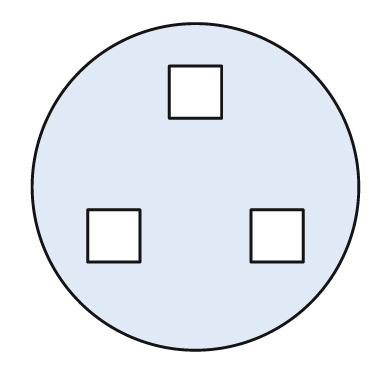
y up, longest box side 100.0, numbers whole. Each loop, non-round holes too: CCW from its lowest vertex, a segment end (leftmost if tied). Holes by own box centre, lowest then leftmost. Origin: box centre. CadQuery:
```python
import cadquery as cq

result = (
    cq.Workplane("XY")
    .moveTo(0.0, 0.0)
    .circle(50.0)
    .moveTo(-33.0, -23.0)
    .lineTo(-17.0, -23.0)
    .lineTo(-17.0, -7.0)
    .lineTo(-33.0, -7.0)
    .close()
    .moveTo(17.0, -23.0)
    .lineTo(33.0, -23.0)
    .lineTo(33.0, -7.0)
    .lineTo(17.0, -7.0)
    .close()
    .moveTo(-8.0, 21.0)
    .lineTo(8.0, 21.0)
    .lineTo(8.0, 37.0)
    .lineTo(-8.0, 37.0)
    .close()
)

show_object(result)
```